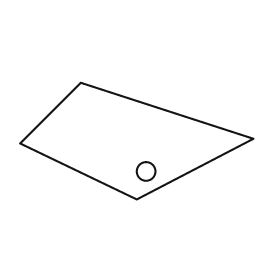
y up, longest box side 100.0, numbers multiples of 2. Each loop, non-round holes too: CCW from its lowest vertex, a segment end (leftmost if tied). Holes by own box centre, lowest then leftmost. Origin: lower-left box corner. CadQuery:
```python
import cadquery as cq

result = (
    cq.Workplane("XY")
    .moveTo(50.0, 0.0)
    .lineTo(100.0, 26.0)
    .lineTo(26.0, 50.0)
    .lineTo(0.0, 24.0)
    .close()
    .moveTo(54.0, 12.0)
    .circle(4.0)
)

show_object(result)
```